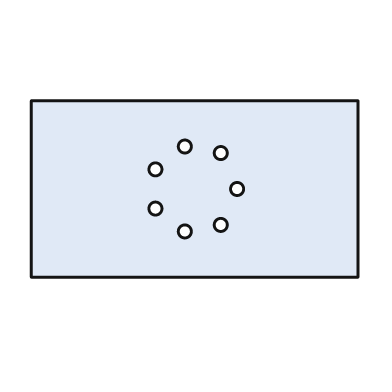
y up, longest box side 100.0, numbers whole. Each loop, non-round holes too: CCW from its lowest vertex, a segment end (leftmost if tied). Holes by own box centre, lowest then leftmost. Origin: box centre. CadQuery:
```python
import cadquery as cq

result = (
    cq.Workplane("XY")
    .moveTo(-50.0, -27.0)
    .lineTo(50.0, -27.0)
    .lineTo(50.0, 27.0)
    .lineTo(-50.0, 27.0)
    .close()
    .moveTo(-3.0, -13.0)
    .circle(2.0)
    .moveTo(8.0, -11.0)
    .circle(2.0)
    .moveTo(-12.0, -6.0)
    .circle(2.0)
    .moveTo(13.0, 0.0)
    .circle(2.0)
    .moveTo(-12.0, 6.0)
    .circle(2.0)
    .moveTo(8.0, 11.0)
    .circle(2.0)
    .moveTo(-3.0, 13.0)
    .circle(2.0)
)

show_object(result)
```